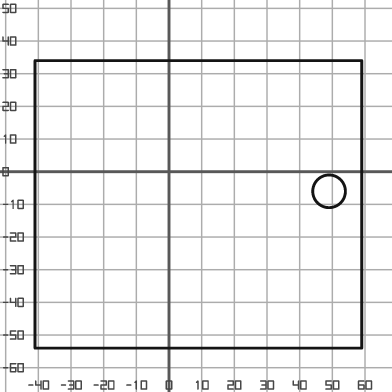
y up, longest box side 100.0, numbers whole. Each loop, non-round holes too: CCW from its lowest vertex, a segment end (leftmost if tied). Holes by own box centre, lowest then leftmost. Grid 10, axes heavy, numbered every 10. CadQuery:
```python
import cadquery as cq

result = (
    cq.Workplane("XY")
    .moveTo(-41.0, -54.0)
    .lineTo(59.0, -54.0)
    .lineTo(59.0, 34.0)
    .lineTo(-41.0, 34.0)
    .close()
    .moveTo(49.0, -6.0)
    .circle(5.0)
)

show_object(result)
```